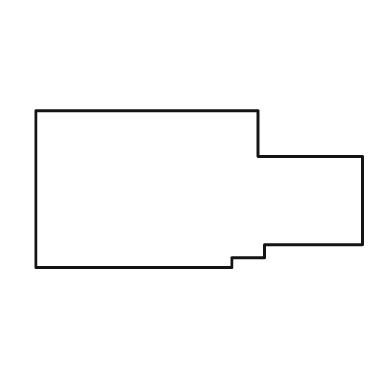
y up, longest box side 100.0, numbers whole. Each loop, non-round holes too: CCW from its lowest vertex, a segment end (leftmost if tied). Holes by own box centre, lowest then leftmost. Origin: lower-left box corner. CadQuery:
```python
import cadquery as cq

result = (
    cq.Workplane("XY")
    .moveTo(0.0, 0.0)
    .lineTo(60.0, 0.0)
    .lineTo(60.0, 3.0)
    .lineTo(70.0, 3.0)
    .lineTo(70.0, 7.0)
    .lineTo(100.0, 7.0)
    .lineTo(100.0, 34.0)
    .lineTo(68.0, 34.0)
    .lineTo(68.0, 48.0)
    .lineTo(0.0, 48.0)
    .close()
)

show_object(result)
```